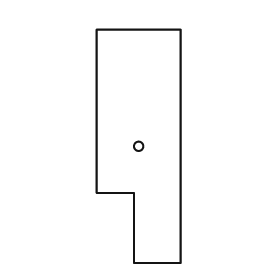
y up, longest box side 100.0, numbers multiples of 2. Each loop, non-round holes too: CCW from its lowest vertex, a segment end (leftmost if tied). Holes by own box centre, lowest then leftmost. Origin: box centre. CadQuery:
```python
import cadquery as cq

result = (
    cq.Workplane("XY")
    .moveTo(-2.0, -50.0)
    .lineTo(18.0, -50.0)
    .lineTo(18.0, 50.0)
    .lineTo(-18.0, 50.0)
    .lineTo(-18.0, -20.0)
    .lineTo(-2.0, -20.0)
    .close()
    .moveTo(0.0, 0.0)
    .circle(2.0)
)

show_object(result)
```